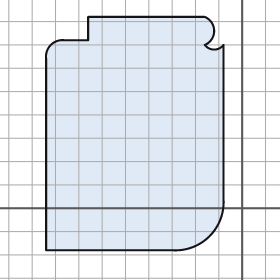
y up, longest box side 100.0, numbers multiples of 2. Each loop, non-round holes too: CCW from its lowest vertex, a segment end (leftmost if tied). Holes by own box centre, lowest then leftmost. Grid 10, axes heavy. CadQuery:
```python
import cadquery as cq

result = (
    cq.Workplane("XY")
    .moveTo(-84.0, -18.0)
    .lineTo(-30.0, -18.0)
    .threePointArc((-14.0, -12.0), (-8.0, 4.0))
    .lineTo(-8.0, 70.0)
    .threePointArc((-12.0, 68.0), (-16.0, 70.0))
    .threePointArc((-12.0, 76.0), (-16.0, 82.0))
    .lineTo(-66.0, 82.0)
    .lineTo(-66.0, 72.0)
    .lineTo(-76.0, 72.0)
    .threePointArc((-82.0, 70.0), (-84.0, 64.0))
    .close()
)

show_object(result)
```